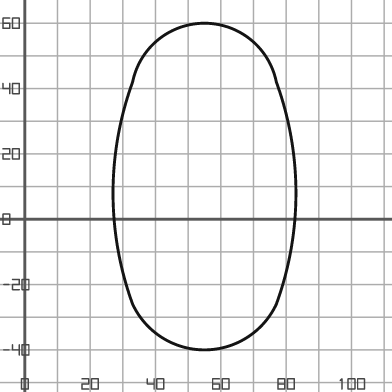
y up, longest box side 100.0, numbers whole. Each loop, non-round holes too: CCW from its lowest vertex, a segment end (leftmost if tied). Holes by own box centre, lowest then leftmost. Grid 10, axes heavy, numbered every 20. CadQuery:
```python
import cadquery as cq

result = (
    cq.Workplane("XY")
    .moveTo(33.0, -26.0)
    .threePointArc((55.0, -40.0), (77.0, -26.0))
    .threePointArc((83.0, 8.0), (77.0, 42.0))
    .threePointArc((55.0, 60.0), (33.0, 42.0))
    .threePointArc((27.0, 8.0), (33.0, -26.0))
    .close()
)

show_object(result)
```